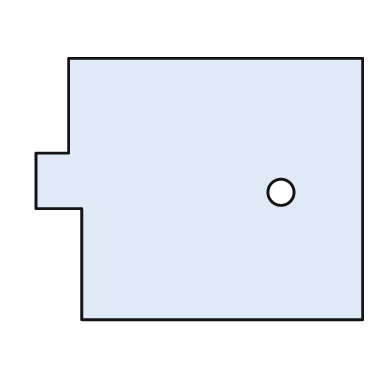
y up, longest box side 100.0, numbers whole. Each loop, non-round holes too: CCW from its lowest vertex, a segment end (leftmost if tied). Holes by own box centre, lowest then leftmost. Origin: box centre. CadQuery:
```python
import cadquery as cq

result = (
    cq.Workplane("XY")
    .moveTo(-36.0, -40.0)
    .lineTo(50.0, -40.0)
    .lineTo(50.0, 40.0)
    .lineTo(-40.0, 40.0)
    .lineTo(-40.0, 11.0)
    .lineTo(-50.0, 11.0)
    .lineTo(-50.0, -6.0)
    .lineTo(-36.0, -6.0)
    .close()
    .moveTo(25.0, -1.0)
    .circle(4.0)
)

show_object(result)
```